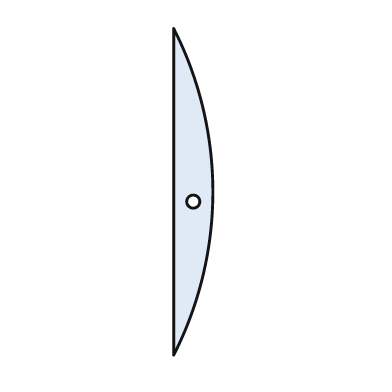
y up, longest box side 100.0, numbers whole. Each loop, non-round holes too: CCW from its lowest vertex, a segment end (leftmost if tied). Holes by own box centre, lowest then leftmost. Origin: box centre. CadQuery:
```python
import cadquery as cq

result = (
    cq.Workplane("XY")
    .moveTo(-6.0, -50.0)
    .threePointArc((6.0, 0.0), (-6.0, 50.0))
    .close()
    .moveTo(0.0, -3.0)
    .circle(2.0)
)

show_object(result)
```